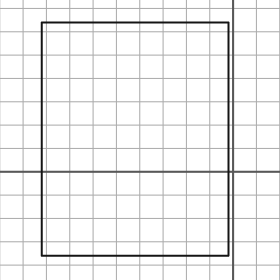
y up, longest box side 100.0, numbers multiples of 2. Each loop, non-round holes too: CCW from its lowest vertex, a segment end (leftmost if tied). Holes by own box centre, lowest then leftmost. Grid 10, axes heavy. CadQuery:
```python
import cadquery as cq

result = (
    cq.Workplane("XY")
    .moveTo(-82.0, -36.0)
    .lineTo(-2.0, -36.0)
    .lineTo(-2.0, 64.0)
    .lineTo(-82.0, 64.0)
    .close()
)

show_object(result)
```